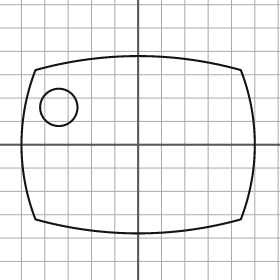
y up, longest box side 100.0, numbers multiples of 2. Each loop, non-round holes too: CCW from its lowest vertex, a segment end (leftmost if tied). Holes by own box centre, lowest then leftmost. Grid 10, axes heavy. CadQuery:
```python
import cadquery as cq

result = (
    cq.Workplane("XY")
    .moveTo(-44.0, -32.0)
    .threePointArc((0.0, -38.0), (44.0, -32.0))
    .threePointArc((50.0, 0.0), (44.0, 32.0))
    .threePointArc((0.0, 38.0), (-44.0, 32.0))
    .threePointArc((-50.0, 0.0), (-44.0, -32.0))
    .close()
    .moveTo(-34.0, 16.0)
    .circle(8.0)
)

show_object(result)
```